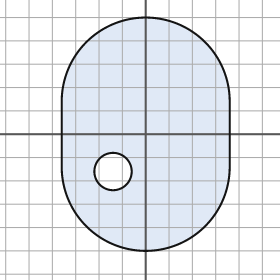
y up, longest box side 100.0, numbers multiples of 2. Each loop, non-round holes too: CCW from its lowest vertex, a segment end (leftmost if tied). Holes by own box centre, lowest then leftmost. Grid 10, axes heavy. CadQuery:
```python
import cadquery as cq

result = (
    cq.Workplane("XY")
    .moveTo(-36.0, -14.0)
    .threePointArc((0.0, -50.0), (36.0, -14.0))
    .lineTo(36.0, 14.0)
    .threePointArc((0.0, 50.0), (-36.0, 14.0))
    .close()
    .moveTo(-14.0, -16.0)
    .circle(8.0)
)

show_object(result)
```